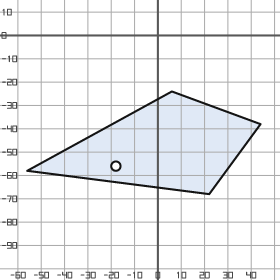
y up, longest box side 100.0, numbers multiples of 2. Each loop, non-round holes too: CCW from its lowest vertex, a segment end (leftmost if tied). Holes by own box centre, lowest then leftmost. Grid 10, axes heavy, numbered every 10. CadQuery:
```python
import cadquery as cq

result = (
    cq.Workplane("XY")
    .moveTo(22.0, -68.0)
    .lineTo(44.0, -38.0)
    .lineTo(6.0, -24.0)
    .lineTo(-56.0, -58.0)
    .close()
    .moveTo(-18.0, -56.0)
    .circle(2.0)
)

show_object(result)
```